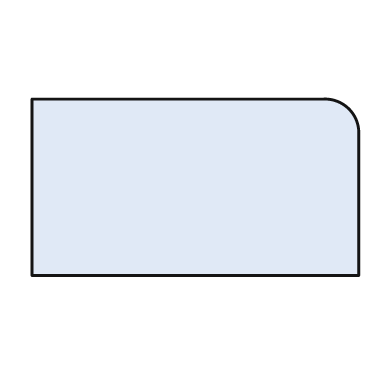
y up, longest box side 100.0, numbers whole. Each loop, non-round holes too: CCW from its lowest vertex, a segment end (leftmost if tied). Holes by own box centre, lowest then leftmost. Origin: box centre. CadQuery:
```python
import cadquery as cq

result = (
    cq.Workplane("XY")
    .moveTo(-50.0, -27.0)
    .lineTo(50.0, -27.0)
    .lineTo(50.0, 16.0)
    .threePointArc((47.0, 24.0), (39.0, 27.0))
    .lineTo(-50.0, 27.0)
    .close()
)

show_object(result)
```